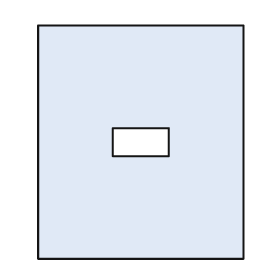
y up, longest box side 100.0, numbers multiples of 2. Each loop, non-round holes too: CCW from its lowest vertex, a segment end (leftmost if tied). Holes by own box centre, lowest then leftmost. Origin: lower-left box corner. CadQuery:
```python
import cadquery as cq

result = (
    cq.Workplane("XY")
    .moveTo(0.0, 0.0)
    .lineTo(88.0, 0.0)
    .lineTo(88.0, 100.0)
    .lineTo(0.0, 100.0)
    .close()
    .moveTo(32.0, 44.0)
    .lineTo(56.0, 44.0)
    .lineTo(56.0, 56.0)
    .lineTo(32.0, 56.0)
    .close()
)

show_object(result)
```